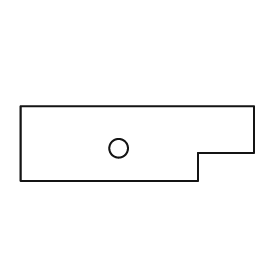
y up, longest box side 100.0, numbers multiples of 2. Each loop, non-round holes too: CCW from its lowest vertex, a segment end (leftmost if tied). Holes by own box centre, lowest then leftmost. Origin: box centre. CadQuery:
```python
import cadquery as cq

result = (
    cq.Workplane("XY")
    .moveTo(-50.0, -16.0)
    .lineTo(26.0, -16.0)
    .lineTo(26.0, -4.0)
    .lineTo(50.0, -4.0)
    .lineTo(50.0, 16.0)
    .lineTo(-50.0, 16.0)
    .close()
    .moveTo(-8.0, -2.0)
    .circle(4.0)
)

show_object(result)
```